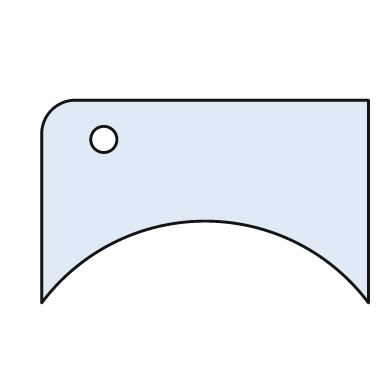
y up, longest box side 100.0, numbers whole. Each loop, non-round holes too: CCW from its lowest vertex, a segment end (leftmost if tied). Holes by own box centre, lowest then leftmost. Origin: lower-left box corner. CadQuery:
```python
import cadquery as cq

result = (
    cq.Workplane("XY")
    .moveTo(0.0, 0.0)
    .threePointArc((50.0, 25.0), (100.0, 0.0))
    .lineTo(100.0, 62.0)
    .lineTo(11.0, 62.0)
    .threePointArc((3.0, 59.0), (0.0, 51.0))
    .close()
    .moveTo(19.0, 50.0)
    .circle(4.0)
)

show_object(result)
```